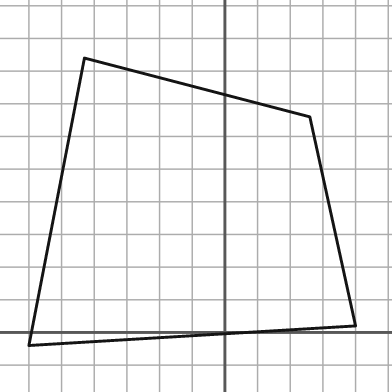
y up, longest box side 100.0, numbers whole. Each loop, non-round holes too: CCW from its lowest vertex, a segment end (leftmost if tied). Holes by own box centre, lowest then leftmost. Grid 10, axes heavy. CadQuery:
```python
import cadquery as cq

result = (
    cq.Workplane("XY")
    .moveTo(-60.0, -4.0)
    .lineTo(40.0, 2.0)
    .lineTo(26.0, 66.0)
    .lineTo(-43.0, 84.0)
    .close()
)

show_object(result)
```